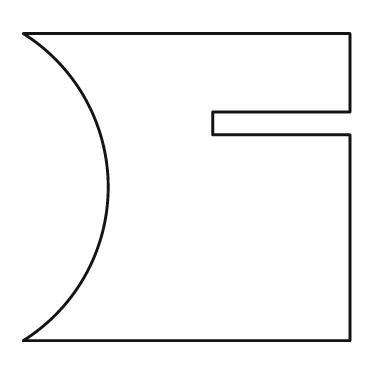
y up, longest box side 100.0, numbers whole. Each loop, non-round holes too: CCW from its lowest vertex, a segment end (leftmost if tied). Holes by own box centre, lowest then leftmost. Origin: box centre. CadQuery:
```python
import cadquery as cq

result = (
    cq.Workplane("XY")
    .moveTo(-50.0, -47.0)
    .lineTo(50.0, -47.0)
    .lineTo(50.0, 16.0)
    .lineTo(8.0, 16.0)
    .lineTo(8.0, 23.0)
    .lineTo(50.0, 23.0)
    .lineTo(50.0, 47.0)
    .lineTo(-50.0, 47.0)
    .threePointArc((-24.0, 0.0), (-50.0, -47.0))
    .close()
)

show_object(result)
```